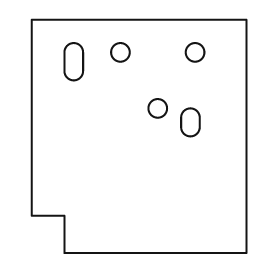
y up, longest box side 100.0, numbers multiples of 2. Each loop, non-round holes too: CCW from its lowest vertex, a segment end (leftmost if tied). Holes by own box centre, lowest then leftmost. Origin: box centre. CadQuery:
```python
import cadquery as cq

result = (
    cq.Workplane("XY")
    .moveTo(-32.0, -50.0)
    .lineTo(46.0, -50.0)
    .lineTo(46.0, 50.0)
    .lineTo(-46.0, 50.0)
    .lineTo(-46.0, -34.0)
    .lineTo(-32.0, -34.0)
    .close()
    .moveTo(18.0, 4.0)
    .threePointArc((22.0, 0.0), (26.0, 4.0))
    .lineTo(26.0, 8.0)
    .threePointArc((22.0, 12.0), (18.0, 8.0))
    .close()
    .moveTo(8.0, 12.0)
    .circle(4.0)
    .moveTo(-32.0, 28.0)
    .threePointArc((-28.0, 24.0), (-24.0, 28.0))
    .lineTo(-24.0, 36.0)
    .threePointArc((-28.0, 40.0), (-32.0, 36.0))
    .close()
    .moveTo(-8.0, 36.0)
    .circle(4.0)
    .moveTo(24.0, 36.0)
    .circle(4.0)
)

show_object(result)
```